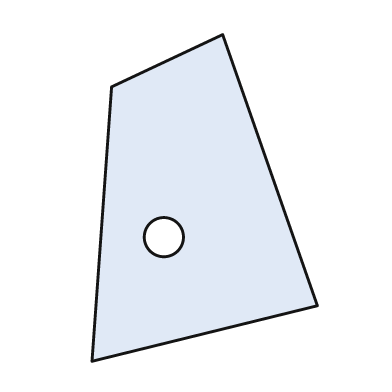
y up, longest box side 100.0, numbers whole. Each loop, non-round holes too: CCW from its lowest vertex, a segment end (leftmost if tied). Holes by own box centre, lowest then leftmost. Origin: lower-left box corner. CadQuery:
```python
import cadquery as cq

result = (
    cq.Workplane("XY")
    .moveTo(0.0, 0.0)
    .lineTo(69.0, 17.0)
    .lineTo(40.0, 100.0)
    .lineTo(6.0, 84.0)
    .close()
    .moveTo(22.0, 38.0)
    .circle(6.0)
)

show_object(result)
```